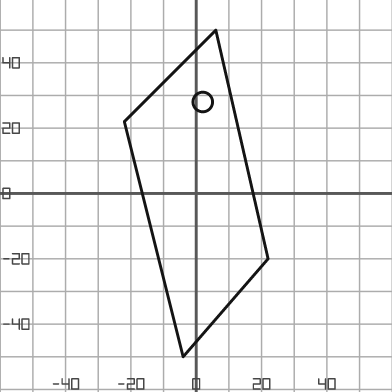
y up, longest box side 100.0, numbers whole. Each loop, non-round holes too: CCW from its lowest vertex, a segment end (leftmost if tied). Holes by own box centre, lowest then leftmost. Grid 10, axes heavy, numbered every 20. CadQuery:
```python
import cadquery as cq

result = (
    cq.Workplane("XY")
    .moveTo(-4.0, -50.0)
    .lineTo(22.0, -20.0)
    .lineTo(6.0, 50.0)
    .lineTo(-22.0, 22.0)
    .close()
    .moveTo(2.0, 28.0)
    .circle(3.0)
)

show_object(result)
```